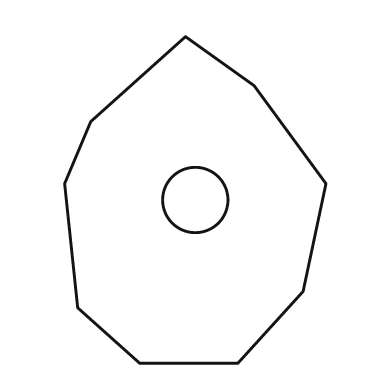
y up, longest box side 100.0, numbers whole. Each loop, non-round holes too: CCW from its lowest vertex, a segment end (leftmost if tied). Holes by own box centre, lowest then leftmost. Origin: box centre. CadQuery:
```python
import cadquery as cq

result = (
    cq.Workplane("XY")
    .moveTo(-17.0, -50.0)
    .lineTo(13.0, -50.0)
    .lineTo(33.0, -28.0)
    .lineTo(40.0, 5.0)
    .lineTo(18.0, 35.0)
    .lineTo(-3.0, 50.0)
    .lineTo(-32.0, 24.0)
    .lineTo(-40.0, 5.0)
    .lineTo(-36.0, -33.0)
    .close()
    .moveTo(0.0, 0.0)
    .circle(10.0)
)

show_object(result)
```